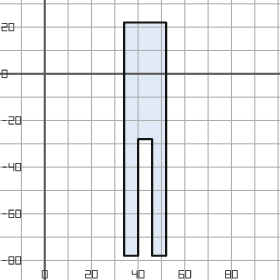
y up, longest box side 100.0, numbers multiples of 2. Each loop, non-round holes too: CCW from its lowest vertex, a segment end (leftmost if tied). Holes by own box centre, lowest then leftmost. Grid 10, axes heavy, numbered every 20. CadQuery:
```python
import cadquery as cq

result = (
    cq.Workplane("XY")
    .moveTo(34.0, -78.0)
    .lineTo(40.0, -78.0)
    .lineTo(40.0, -28.0)
    .lineTo(46.0, -28.0)
    .lineTo(46.0, -78.0)
    .lineTo(52.0, -78.0)
    .lineTo(52.0, 22.0)
    .lineTo(34.0, 22.0)
    .close()
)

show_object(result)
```